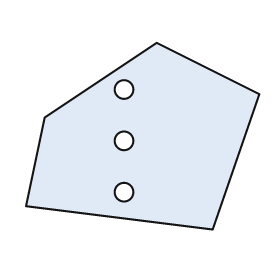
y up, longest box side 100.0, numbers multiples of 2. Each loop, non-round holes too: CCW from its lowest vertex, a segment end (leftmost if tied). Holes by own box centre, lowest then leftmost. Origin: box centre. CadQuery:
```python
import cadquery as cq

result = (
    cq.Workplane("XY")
    .moveTo(30.0, -40.0)
    .lineTo(50.0, 18.0)
    .lineTo(6.0, 40.0)
    .lineTo(-42.0, 8.0)
    .lineTo(-50.0, -30.0)
    .close()
    .moveTo(-8.0, -24.0)
    .circle(4.0)
    .moveTo(-8.0, -2.0)
    .circle(4.0)
    .moveTo(-8.0, 20.0)
    .circle(4.0)
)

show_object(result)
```